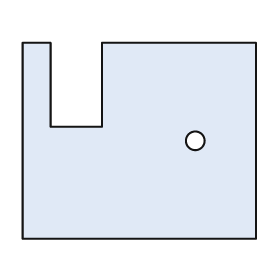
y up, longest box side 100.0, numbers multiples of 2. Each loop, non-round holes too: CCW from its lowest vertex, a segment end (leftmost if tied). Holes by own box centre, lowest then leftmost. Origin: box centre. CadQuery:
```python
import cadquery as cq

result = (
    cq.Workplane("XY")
    .moveTo(-50.0, -42.0)
    .lineTo(50.0, -42.0)
    .lineTo(50.0, 42.0)
    .lineTo(-16.0, 42.0)
    .lineTo(-16.0, 6.0)
    .lineTo(-38.0, 6.0)
    .lineTo(-38.0, 42.0)
    .lineTo(-50.0, 42.0)
    .close()
    .moveTo(24.0, 0.0)
    .circle(4.0)
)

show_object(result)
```